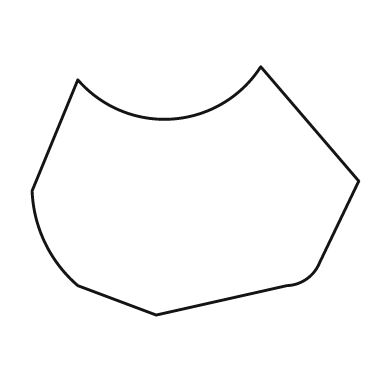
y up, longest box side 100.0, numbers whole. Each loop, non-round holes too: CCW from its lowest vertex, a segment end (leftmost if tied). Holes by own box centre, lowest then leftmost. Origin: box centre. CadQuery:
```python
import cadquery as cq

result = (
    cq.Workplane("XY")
    .moveTo(-12.0, -38.0)
    .lineTo(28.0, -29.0)
    .threePointArc((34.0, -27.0), (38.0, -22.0))
    .lineTo(50.0, 3.0)
    .lineTo(20.0, 38.0)
    .threePointArc((-7.0, 22.0), (-36.0, 34.0))
    .lineTo(-50.0, 0.0)
    .threePointArc((-46.0, -16.0), (-36.0, -29.0))
    .close()
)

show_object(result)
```